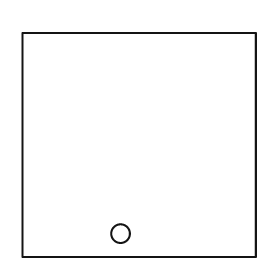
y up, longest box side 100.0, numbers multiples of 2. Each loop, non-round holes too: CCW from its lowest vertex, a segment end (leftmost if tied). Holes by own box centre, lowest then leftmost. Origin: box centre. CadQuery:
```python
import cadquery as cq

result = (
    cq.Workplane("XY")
    .moveTo(-50.0, -48.0)
    .lineTo(50.0, -48.0)
    .lineTo(50.0, 48.0)
    .lineTo(-50.0, 48.0)
    .close()
    .moveTo(-8.0, -38.0)
    .circle(4.0)
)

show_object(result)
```